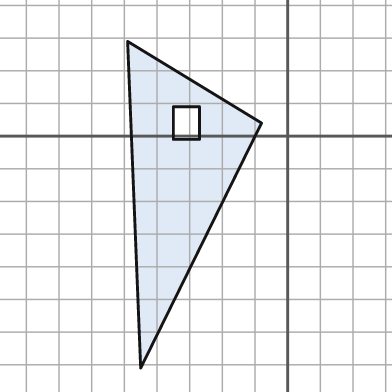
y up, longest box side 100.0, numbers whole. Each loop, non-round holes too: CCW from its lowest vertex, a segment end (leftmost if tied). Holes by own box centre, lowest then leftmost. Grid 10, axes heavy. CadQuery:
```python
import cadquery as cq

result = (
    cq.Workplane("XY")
    .moveTo(-45.0, -71.0)
    .lineTo(-8.0, 4.0)
    .lineTo(-49.0, 29.0)
    .close()
    .moveTo(-35.0, -1.0)
    .lineTo(-27.0, -1.0)
    .lineTo(-27.0, 9.0)
    .lineTo(-35.0, 9.0)
    .close()
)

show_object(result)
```